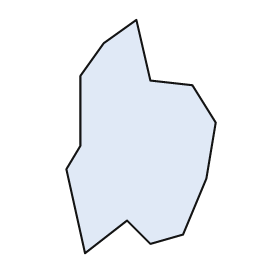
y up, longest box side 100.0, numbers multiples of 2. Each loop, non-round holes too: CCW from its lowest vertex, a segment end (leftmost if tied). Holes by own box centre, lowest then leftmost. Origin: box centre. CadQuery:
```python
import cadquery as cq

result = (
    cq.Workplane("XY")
    .moveTo(-24.0, -50.0)
    .lineTo(-6.0, -36.0)
    .lineTo(4.0, -46.0)
    .lineTo(18.0, -42.0)
    .lineTo(28.0, -18.0)
    .lineTo(32.0, 6.0)
    .lineTo(22.0, 22.0)
    .lineTo(4.0, 24.0)
    .lineTo(-2.0, 50.0)
    .lineTo(-16.0, 40.0)
    .lineTo(-26.0, 26.0)
    .lineTo(-26.0, -4.0)
    .lineTo(-32.0, -14.0)
    .close()
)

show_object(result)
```